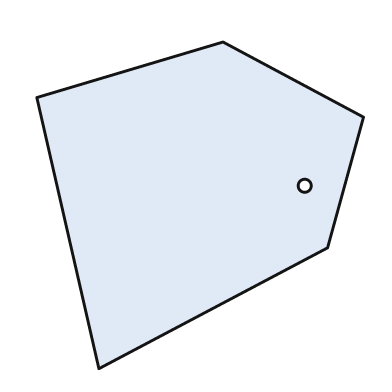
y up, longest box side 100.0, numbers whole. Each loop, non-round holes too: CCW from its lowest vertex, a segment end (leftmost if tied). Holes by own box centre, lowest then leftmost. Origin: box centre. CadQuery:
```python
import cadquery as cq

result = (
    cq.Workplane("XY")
    .moveTo(-31.0, -50.0)
    .lineTo(39.0, -13.0)
    .lineTo(50.0, 27.0)
    .lineTo(7.0, 50.0)
    .lineTo(-50.0, 33.0)
    .close()
    .moveTo(32.0, 6.0)
    .circle(2.0)
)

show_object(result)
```